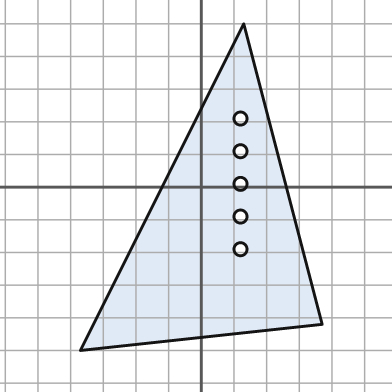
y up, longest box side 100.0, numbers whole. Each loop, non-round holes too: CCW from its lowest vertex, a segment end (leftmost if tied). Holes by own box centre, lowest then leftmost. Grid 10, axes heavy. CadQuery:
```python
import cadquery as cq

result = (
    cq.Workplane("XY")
    .moveTo(-37.0, -50.0)
    .lineTo(37.0, -42.0)
    .lineTo(13.0, 50.0)
    .close()
    .moveTo(12.0, -19.0)
    .circle(2.0)
    .moveTo(12.0, -9.0)
    .circle(2.0)
    .moveTo(12.0, 1.0)
    .circle(2.0)
    .moveTo(12.0, 11.0)
    .circle(2.0)
    .moveTo(12.0, 21.0)
    .circle(2.0)
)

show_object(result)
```